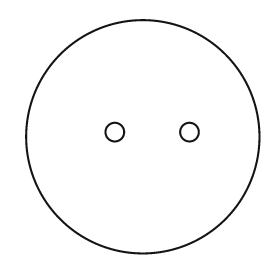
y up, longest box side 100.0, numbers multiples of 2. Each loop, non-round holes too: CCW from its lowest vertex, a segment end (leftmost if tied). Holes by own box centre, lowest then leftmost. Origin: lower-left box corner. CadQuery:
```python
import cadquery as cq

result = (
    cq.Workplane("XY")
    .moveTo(50.0, 50.0)
    .circle(50.0)
    .moveTo(38.0, 52.0)
    .circle(4.0)
    .moveTo(70.0, 52.0)
    .circle(4.0)
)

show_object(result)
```